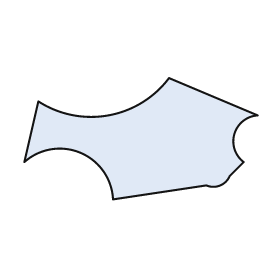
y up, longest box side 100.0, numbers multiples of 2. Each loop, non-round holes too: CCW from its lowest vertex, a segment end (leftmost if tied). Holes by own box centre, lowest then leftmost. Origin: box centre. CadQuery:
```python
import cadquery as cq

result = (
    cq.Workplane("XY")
    .moveTo(-12.0, -26.0)
    .lineTo(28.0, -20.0)
    .threePointArc((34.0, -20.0), (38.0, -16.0))
    .lineTo(44.0, -10.0)
    .threePointArc((40.0, 2.0), (50.0, 10.0))
    .lineTo(12.0, 26.0)
    .threePointArc((-14.0, 10.0), (-44.0, 16.0))
    .lineTo(-50.0, -10.0)
    .threePointArc((-26.0, -6.0), (-12.0, -26.0))
    .close()
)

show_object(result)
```